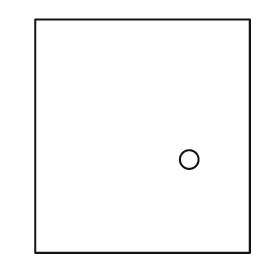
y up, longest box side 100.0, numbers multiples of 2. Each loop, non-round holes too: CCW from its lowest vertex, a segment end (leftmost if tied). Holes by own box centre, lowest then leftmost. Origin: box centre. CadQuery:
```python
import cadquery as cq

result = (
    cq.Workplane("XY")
    .moveTo(-46.0, -50.0)
    .lineTo(46.0, -50.0)
    .lineTo(46.0, 50.0)
    .lineTo(-46.0, 50.0)
    .close()
    .moveTo(20.0, -10.0)
    .circle(4.0)
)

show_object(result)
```